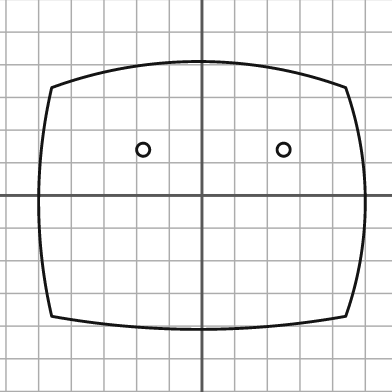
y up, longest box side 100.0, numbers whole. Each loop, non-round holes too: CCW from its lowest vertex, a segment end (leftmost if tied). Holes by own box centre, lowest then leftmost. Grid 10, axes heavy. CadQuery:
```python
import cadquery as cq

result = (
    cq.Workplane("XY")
    .moveTo(-46.0, -37.0)
    .threePointArc((-1.0, -41.0), (44.0, -37.0))
    .threePointArc((50.0, -2.0), (44.0, 33.0))
    .threePointArc((-1.0, 41.0), (-46.0, 33.0))
    .threePointArc((-50.0, -2.0), (-46.0, -37.0))
    .close()
    .moveTo(-18.0, 14.0)
    .circle(2.0)
    .moveTo(25.0, 14.0)
    .circle(2.0)
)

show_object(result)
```